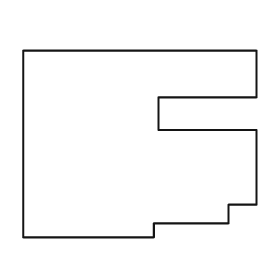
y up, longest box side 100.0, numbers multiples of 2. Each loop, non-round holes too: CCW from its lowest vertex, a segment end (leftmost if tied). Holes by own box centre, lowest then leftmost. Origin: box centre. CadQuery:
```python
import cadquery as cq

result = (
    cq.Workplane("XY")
    .moveTo(-50.0, -40.0)
    .lineTo(6.0, -40.0)
    .lineTo(6.0, -34.0)
    .lineTo(38.0, -34.0)
    .lineTo(38.0, -26.0)
    .lineTo(50.0, -26.0)
    .lineTo(50.0, 6.0)
    .lineTo(8.0, 6.0)
    .lineTo(8.0, 20.0)
    .lineTo(50.0, 20.0)
    .lineTo(50.0, 40.0)
    .lineTo(-50.0, 40.0)
    .close()
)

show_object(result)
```